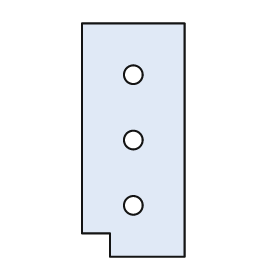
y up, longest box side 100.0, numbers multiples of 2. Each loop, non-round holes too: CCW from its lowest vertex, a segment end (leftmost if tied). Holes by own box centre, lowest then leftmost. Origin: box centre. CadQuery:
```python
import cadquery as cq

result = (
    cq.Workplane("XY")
    .moveTo(-10.0, -50.0)
    .lineTo(22.0, -50.0)
    .lineTo(22.0, 50.0)
    .lineTo(-22.0, 50.0)
    .lineTo(-22.0, -40.0)
    .lineTo(-10.0, -40.0)
    .close()
    .moveTo(0.0, -28.0)
    .circle(4.0)
    .moveTo(0.0, 0.0)
    .circle(4.0)
    .moveTo(0.0, 28.0)
    .circle(4.0)
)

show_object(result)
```